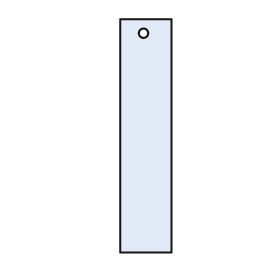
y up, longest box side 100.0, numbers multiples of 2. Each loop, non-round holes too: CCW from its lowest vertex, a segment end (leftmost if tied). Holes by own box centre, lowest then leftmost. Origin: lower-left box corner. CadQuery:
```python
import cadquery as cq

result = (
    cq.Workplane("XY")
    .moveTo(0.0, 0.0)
    .lineTo(22.0, 0.0)
    .lineTo(22.0, 100.0)
    .lineTo(0.0, 100.0)
    .close()
    .moveTo(10.0, 94.0)
    .circle(2.0)
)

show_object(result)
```